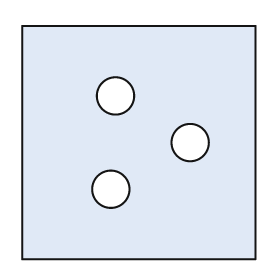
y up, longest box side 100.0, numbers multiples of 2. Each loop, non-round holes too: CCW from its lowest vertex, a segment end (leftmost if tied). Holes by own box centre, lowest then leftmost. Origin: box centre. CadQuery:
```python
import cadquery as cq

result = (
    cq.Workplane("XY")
    .moveTo(-50.0, -50.0)
    .lineTo(50.0, -50.0)
    .lineTo(50.0, 50.0)
    .lineTo(-50.0, 50.0)
    .close()
    .moveTo(-12.0, -20.0)
    .circle(8.0)
    .moveTo(22.0, 0.0)
    .circle(8.0)
    .moveTo(-10.0, 20.0)
    .circle(8.0)
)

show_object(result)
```